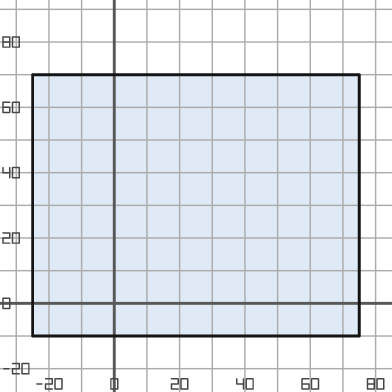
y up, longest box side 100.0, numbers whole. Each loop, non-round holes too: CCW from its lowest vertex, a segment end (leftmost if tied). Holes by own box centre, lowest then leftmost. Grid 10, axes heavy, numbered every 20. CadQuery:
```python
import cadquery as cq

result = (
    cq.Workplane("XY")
    .moveTo(-25.0, -10.0)
    .lineTo(75.0, -10.0)
    .lineTo(75.0, 70.0)
    .lineTo(-25.0, 70.0)
    .close()
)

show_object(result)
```